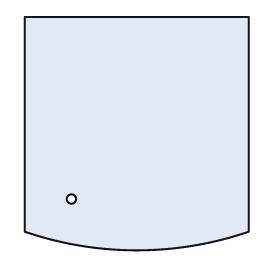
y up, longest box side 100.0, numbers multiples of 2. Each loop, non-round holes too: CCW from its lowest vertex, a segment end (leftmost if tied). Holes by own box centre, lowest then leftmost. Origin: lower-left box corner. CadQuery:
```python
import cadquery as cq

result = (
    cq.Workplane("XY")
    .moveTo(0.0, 8.0)
    .threePointArc((48.0, 0.0), (96.0, 8.0))
    .lineTo(96.0, 100.0)
    .lineTo(0.0, 100.0)
    .close()
    .moveTo(20.0, 22.0)
    .circle(2.0)
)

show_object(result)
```